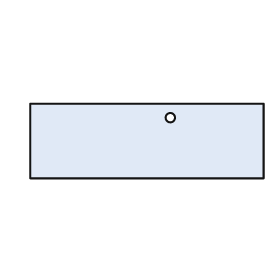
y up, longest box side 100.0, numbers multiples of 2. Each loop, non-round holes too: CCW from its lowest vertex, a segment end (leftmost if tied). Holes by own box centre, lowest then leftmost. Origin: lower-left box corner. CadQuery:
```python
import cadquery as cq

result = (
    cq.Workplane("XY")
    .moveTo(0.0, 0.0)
    .lineTo(100.0, 0.0)
    .lineTo(100.0, 32.0)
    .lineTo(0.0, 32.0)
    .close()
    .moveTo(60.0, 26.0)
    .circle(2.0)
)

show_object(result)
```